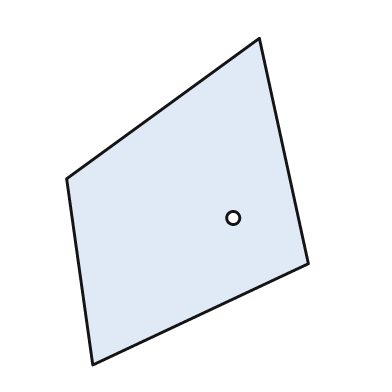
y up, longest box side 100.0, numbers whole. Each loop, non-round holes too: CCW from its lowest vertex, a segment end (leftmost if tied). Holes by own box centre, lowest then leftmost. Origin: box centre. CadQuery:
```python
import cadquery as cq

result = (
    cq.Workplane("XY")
    .moveTo(-29.0, -50.0)
    .lineTo(37.0, -19.0)
    .lineTo(22.0, 50.0)
    .lineTo(-37.0, 7.0)
    .close()
    .moveTo(14.0, -5.0)
    .circle(2.0)
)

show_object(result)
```